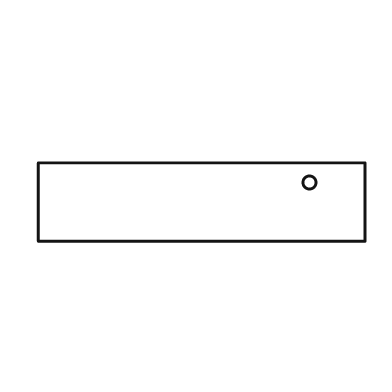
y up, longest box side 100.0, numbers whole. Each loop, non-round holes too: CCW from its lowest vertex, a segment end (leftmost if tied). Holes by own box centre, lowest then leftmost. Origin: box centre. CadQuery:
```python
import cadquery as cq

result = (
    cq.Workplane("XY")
    .moveTo(-50.0, -12.0)
    .lineTo(50.0, -12.0)
    .lineTo(50.0, 12.0)
    .lineTo(-50.0, 12.0)
    .close()
    .moveTo(33.0, 6.0)
    .circle(2.0)
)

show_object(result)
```